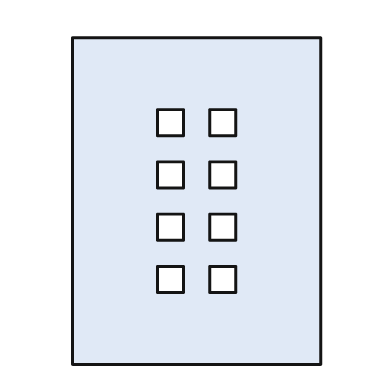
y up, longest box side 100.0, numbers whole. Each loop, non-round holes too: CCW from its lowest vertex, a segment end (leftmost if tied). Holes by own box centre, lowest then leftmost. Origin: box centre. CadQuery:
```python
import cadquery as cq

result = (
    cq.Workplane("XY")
    .moveTo(-38.0, -50.0)
    .lineTo(38.0, -50.0)
    .lineTo(38.0, 50.0)
    .lineTo(-38.0, 50.0)
    .close()
    .moveTo(-12.0, -28.0)
    .lineTo(-4.0, -28.0)
    .lineTo(-4.0, -20.0)
    .lineTo(-12.0, -20.0)
    .close()
    .moveTo(4.0, -28.0)
    .lineTo(12.0, -28.0)
    .lineTo(12.0, -20.0)
    .lineTo(4.0, -20.0)
    .close()
    .moveTo(-12.0, -12.0)
    .lineTo(-4.0, -12.0)
    .lineTo(-4.0, -4.0)
    .lineTo(-12.0, -4.0)
    .close()
    .moveTo(4.0, -12.0)
    .lineTo(12.0, -12.0)
    .lineTo(12.0, -4.0)
    .lineTo(4.0, -4.0)
    .close()
    .moveTo(-12.0, 4.0)
    .lineTo(-4.0, 4.0)
    .lineTo(-4.0, 12.0)
    .lineTo(-12.0, 12.0)
    .close()
    .moveTo(4.0, 4.0)
    .lineTo(12.0, 4.0)
    .lineTo(12.0, 12.0)
    .lineTo(4.0, 12.0)
    .close()
    .moveTo(-12.0, 20.0)
    .lineTo(-4.0, 20.0)
    .lineTo(-4.0, 28.0)
    .lineTo(-12.0, 28.0)
    .close()
    .moveTo(4.0, 20.0)
    .lineTo(12.0, 20.0)
    .lineTo(12.0, 28.0)
    .lineTo(4.0, 28.0)
    .close()
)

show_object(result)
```